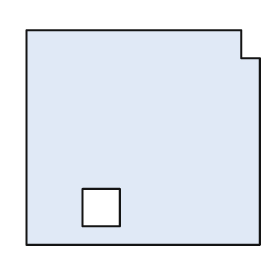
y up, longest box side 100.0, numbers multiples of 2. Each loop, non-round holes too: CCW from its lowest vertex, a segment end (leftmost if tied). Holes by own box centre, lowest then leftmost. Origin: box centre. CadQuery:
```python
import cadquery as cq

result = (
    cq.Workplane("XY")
    .moveTo(-50.0, -46.0)
    .lineTo(50.0, -46.0)
    .lineTo(50.0, 34.0)
    .lineTo(42.0, 34.0)
    .lineTo(42.0, 46.0)
    .lineTo(-50.0, 46.0)
    .close()
    .moveTo(-26.0, -38.0)
    .lineTo(-10.0, -38.0)
    .lineTo(-10.0, -22.0)
    .lineTo(-26.0, -22.0)
    .close()
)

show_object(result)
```